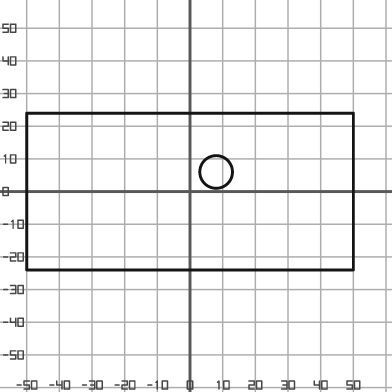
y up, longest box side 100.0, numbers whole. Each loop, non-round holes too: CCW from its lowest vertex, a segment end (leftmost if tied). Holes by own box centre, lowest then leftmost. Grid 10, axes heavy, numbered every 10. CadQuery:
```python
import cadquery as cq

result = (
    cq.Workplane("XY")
    .moveTo(-50.0, -24.0)
    .lineTo(50.0, -24.0)
    .lineTo(50.0, 24.0)
    .lineTo(-50.0, 24.0)
    .close()
    .moveTo(8.0, 6.0)
    .circle(5.0)
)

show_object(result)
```